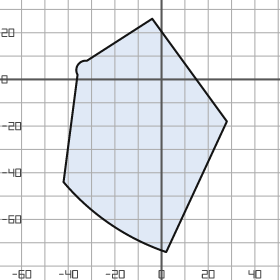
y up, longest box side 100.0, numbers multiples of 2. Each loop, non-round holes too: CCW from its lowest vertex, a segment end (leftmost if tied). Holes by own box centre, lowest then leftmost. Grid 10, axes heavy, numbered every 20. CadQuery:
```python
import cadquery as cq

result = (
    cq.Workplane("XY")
    .moveTo(2.0, -74.0)
    .lineTo(28.0, -18.0)
    .lineTo(-4.0, 26.0)
    .lineTo(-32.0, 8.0)
    .threePointArc((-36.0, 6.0), (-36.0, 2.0))
    .lineTo(-42.0, -44.0)
    .threePointArc((-22.0, -62.0), (2.0, -74.0))
    .close()
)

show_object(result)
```